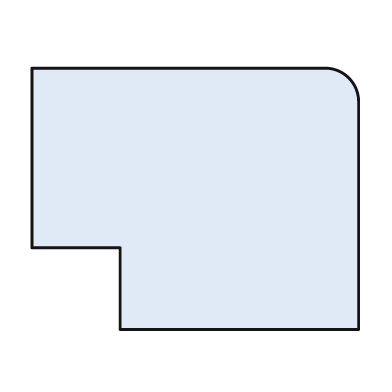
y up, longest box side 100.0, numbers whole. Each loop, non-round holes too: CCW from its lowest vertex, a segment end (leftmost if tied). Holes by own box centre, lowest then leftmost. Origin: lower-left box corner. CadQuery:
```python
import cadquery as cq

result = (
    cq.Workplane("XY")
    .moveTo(27.0, 0.0)
    .lineTo(100.0, 0.0)
    .lineTo(100.0, 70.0)
    .threePointArc((97.0, 77.0), (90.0, 80.0))
    .lineTo(0.0, 80.0)
    .lineTo(0.0, 25.0)
    .lineTo(27.0, 25.0)
    .close()
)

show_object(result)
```